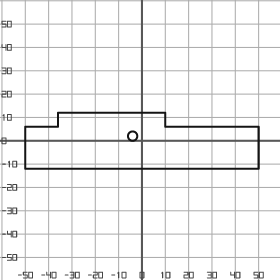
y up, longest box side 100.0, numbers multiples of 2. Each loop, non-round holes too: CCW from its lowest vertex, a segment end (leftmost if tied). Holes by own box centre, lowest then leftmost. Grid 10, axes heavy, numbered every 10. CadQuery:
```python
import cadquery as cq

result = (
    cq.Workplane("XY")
    .moveTo(-50.0, -12.0)
    .lineTo(50.0, -12.0)
    .lineTo(50.0, 6.0)
    .lineTo(10.0, 6.0)
    .lineTo(10.0, 12.0)
    .lineTo(-36.0, 12.0)
    .lineTo(-36.0, 6.0)
    .lineTo(-50.0, 6.0)
    .close()
    .moveTo(-4.0, 2.0)
    .circle(2.0)
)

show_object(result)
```